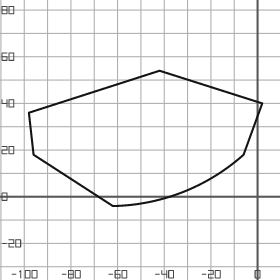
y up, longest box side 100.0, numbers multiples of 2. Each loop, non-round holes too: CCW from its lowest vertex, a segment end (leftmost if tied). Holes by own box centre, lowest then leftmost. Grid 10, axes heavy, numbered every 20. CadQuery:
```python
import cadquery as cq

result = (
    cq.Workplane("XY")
    .moveTo(-62.0, -4.0)
    .threePointArc((-32.0, 2.0), (-6.0, 18.0))
    .lineTo(2.0, 40.0)
    .lineTo(-42.0, 54.0)
    .lineTo(-98.0, 36.0)
    .lineTo(-96.0, 18.0)
    .close()
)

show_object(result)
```